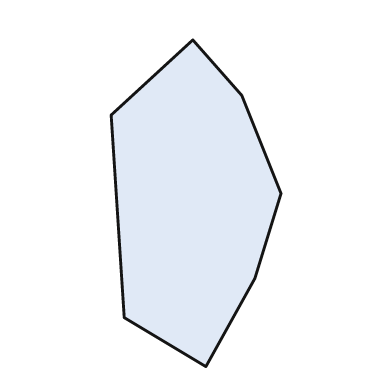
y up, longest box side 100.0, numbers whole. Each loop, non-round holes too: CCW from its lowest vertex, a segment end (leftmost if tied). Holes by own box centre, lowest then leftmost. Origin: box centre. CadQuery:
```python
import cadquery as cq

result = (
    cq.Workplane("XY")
    .moveTo(3.0, -50.0)
    .lineTo(18.0, -23.0)
    .lineTo(26.0, 3.0)
    .lineTo(14.0, 33.0)
    .lineTo(-1.0, 50.0)
    .lineTo(-26.0, 27.0)
    .lineTo(-22.0, -35.0)
    .close()
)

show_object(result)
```